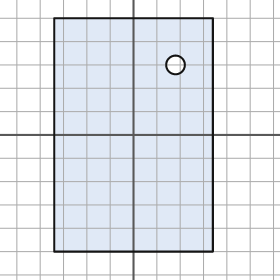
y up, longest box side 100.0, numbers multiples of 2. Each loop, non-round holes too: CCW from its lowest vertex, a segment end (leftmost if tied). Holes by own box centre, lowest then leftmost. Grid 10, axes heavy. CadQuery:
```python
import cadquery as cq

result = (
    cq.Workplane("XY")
    .moveTo(-34.0, -50.0)
    .lineTo(34.0, -50.0)
    .lineTo(34.0, 50.0)
    .lineTo(-34.0, 50.0)
    .close()
    .moveTo(18.0, 30.0)
    .circle(4.0)
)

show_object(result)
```